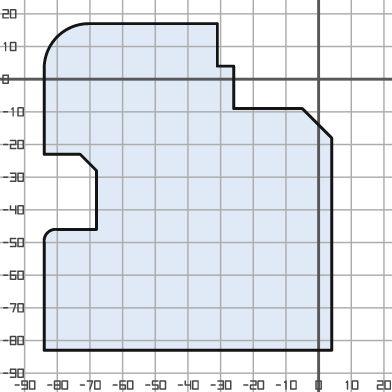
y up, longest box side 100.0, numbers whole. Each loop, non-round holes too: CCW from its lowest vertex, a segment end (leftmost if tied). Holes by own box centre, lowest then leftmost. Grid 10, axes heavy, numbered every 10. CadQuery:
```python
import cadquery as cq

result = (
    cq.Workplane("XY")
    .moveTo(-84.0, -83.0)
    .lineTo(4.0, -83.0)
    .lineTo(4.0, -18.0)
    .lineTo(-5.0, -9.0)
    .lineTo(-26.0, -9.0)
    .lineTo(-26.0, 4.0)
    .lineTo(-31.0, 4.0)
    .lineTo(-31.0, 17.0)
    .lineTo(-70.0, 17.0)
    .threePointArc((-80.0, 13.0), (-84.0, 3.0))
    .lineTo(-84.0, -23.0)
    .lineTo(-73.0, -23.0)
    .lineTo(-68.0, -28.0)
    .lineTo(-68.0, -46.0)
    .lineTo(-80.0, -46.0)
    .threePointArc((-83.0, -47.0), (-84.0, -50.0))
    .close()
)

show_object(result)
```